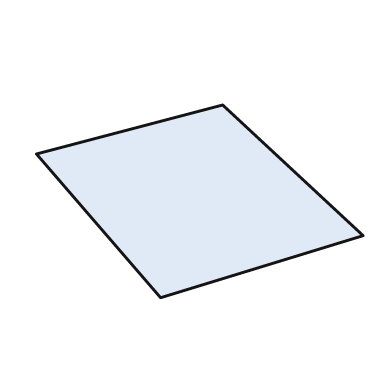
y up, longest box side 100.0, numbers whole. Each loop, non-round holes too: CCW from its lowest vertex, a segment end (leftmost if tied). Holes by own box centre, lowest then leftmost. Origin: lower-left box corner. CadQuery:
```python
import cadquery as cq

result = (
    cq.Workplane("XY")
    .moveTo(38.0, 0.0)
    .lineTo(100.0, 19.0)
    .lineTo(57.0, 59.0)
    .lineTo(0.0, 44.0)
    .close()
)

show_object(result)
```